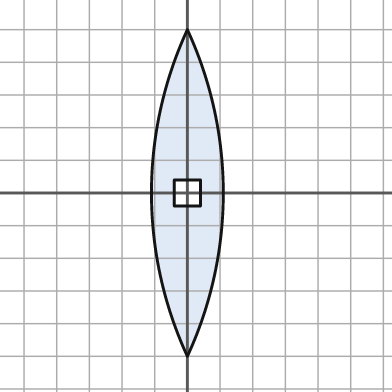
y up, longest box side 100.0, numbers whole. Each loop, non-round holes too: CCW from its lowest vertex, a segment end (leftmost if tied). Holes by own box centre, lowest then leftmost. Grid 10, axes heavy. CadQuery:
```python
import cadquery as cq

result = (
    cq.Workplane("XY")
    .moveTo(0.0, -50.0)
    .threePointArc((11.0, 0.0), (0.0, 50.0))
    .threePointArc((-11.0, 0.0), (0.0, -50.0))
    .close()
    .moveTo(-4.0, -4.0)
    .lineTo(4.0, -4.0)
    .lineTo(4.0, 4.0)
    .lineTo(-4.0, 4.0)
    .close()
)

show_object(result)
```